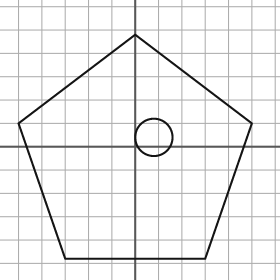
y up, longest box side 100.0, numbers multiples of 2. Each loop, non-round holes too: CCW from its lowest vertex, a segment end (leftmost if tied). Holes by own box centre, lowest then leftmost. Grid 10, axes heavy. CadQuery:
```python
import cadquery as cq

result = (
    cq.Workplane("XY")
    .moveTo(-30.0, -48.0)
    .lineTo(30.0, -48.0)
    .lineTo(50.0, 10.0)
    .lineTo(0.0, 48.0)
    .lineTo(-50.0, 10.0)
    .close()
    .moveTo(8.0, 4.0)
    .circle(8.0)
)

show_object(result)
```